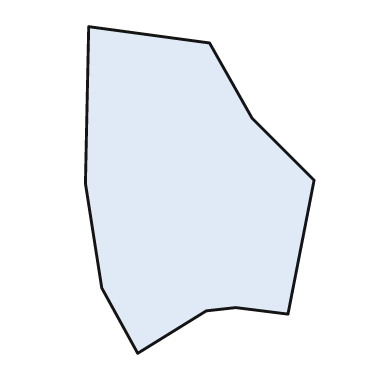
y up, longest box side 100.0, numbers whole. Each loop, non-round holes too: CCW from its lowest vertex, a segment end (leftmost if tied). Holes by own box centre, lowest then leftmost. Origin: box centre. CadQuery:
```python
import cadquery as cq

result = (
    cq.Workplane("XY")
    .moveTo(-19.0, -50.0)
    .lineTo(2.0, -37.0)
    .lineTo(11.0, -36.0)
    .lineTo(27.0, -38.0)
    .lineTo(35.0, 3.0)
    .lineTo(16.0, 22.0)
    .lineTo(3.0, 45.0)
    .lineTo(-34.0, 50.0)
    .lineTo(-35.0, 2.0)
    .lineTo(-30.0, -30.0)
    .close()
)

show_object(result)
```